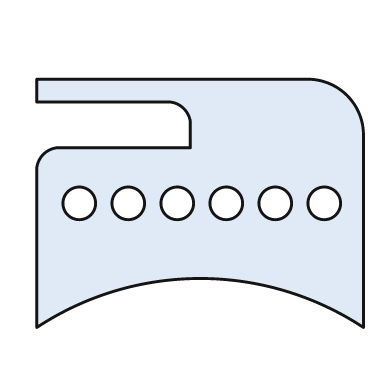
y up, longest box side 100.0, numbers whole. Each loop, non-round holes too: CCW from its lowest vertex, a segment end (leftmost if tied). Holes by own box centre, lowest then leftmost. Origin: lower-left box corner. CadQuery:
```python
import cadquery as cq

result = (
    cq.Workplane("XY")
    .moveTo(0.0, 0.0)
    .threePointArc((50.0, 15.0), (100.0, 0.0))
    .lineTo(100.0, 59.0)
    .threePointArc((95.0, 71.0), (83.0, 76.0))
    .lineTo(0.0, 76.0)
    .lineTo(0.0, 69.0)
    .lineTo(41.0, 69.0)
    .threePointArc((45.0, 67.0), (47.0, 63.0))
    .lineTo(47.0, 55.0)
    .lineTo(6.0, 55.0)
    .threePointArc((2.0, 53.0), (0.0, 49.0))
    .close()
    .moveTo(13.0, 38.0)
    .circle(5.0)
    .moveTo(28.0, 38.0)
    .circle(5.0)
    .moveTo(43.0, 38.0)
    .circle(5.0)
    .moveTo(58.0, 38.0)
    .circle(5.0)
    .moveTo(73.0, 38.0)
    .circle(5.0)
    .moveTo(88.0, 38.0)
    .circle(5.0)
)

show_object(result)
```